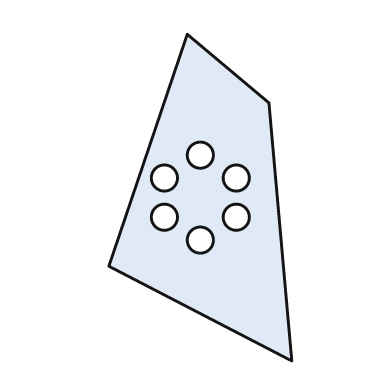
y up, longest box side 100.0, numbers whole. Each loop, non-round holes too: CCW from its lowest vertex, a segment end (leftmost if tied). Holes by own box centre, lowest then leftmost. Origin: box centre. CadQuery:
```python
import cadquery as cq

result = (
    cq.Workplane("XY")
    .moveTo(28.0, -50.0)
    .lineTo(21.0, 29.0)
    .lineTo(-4.0, 50.0)
    .lineTo(-28.0, -21.0)
    .close()
    .moveTo(0.0, -13.0)
    .circle(4.0)
    .moveTo(-11.0, -6.0)
    .circle(4.0)
    .moveTo(11.0, -6.0)
    .circle(4.0)
    .moveTo(-11.0, 6.0)
    .circle(4.0)
    .moveTo(11.0, 6.0)
    .circle(4.0)
    .moveTo(0.0, 13.0)
    .circle(4.0)
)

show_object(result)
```